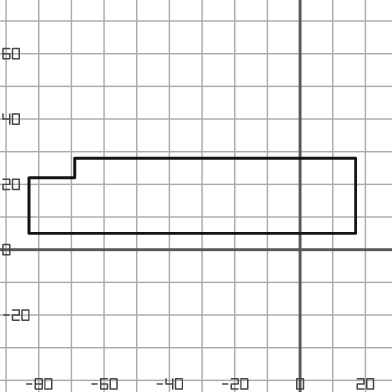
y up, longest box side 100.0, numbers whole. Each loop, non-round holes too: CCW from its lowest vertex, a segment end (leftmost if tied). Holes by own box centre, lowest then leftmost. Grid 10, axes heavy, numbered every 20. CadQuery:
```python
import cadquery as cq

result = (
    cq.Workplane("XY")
    .moveTo(-83.0, 5.0)
    .lineTo(17.0, 5.0)
    .lineTo(17.0, 28.0)
    .lineTo(-69.0, 28.0)
    .lineTo(-69.0, 22.0)
    .lineTo(-83.0, 22.0)
    .close()
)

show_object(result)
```